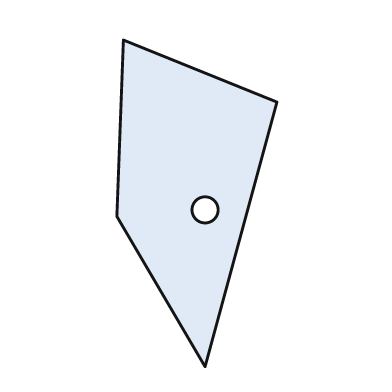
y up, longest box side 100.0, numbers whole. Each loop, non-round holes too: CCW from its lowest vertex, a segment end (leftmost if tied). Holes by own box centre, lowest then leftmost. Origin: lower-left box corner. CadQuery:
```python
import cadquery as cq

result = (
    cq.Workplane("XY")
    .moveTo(27.0, 0.0)
    .lineTo(49.0, 81.0)
    .lineTo(2.0, 100.0)
    .lineTo(0.0, 46.0)
    .close()
    .moveTo(27.0, 48.0)
    .circle(4.0)
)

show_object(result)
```